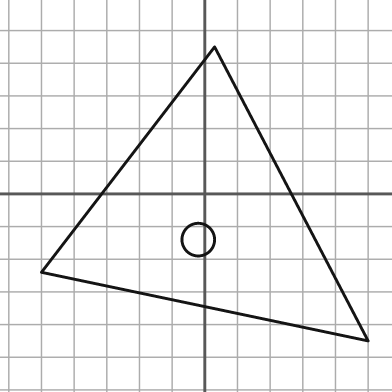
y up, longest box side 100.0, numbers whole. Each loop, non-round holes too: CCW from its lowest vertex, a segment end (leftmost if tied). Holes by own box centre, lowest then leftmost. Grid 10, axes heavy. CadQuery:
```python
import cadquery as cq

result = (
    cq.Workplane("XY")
    .moveTo(50.0, -45.0)
    .lineTo(3.0, 45.0)
    .lineTo(-50.0, -24.0)
    .close()
    .moveTo(-2.0, -14.0)
    .circle(5.0)
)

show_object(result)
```